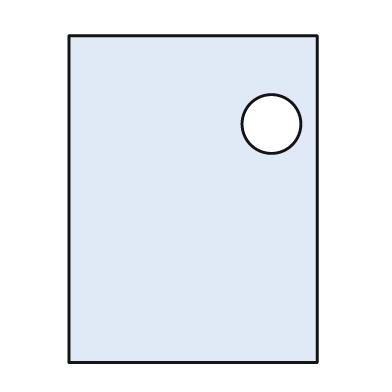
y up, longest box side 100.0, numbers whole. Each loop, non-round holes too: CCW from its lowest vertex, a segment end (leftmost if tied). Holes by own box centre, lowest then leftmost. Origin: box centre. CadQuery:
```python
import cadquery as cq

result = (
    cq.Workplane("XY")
    .moveTo(-38.0, -50.0)
    .lineTo(38.0, -50.0)
    .lineTo(38.0, 50.0)
    .lineTo(-38.0, 50.0)
    .close()
    .moveTo(24.0, 23.0)
    .circle(9.0)
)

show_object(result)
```